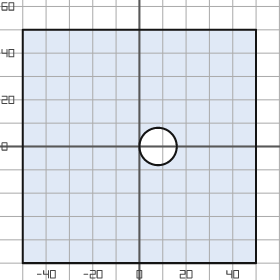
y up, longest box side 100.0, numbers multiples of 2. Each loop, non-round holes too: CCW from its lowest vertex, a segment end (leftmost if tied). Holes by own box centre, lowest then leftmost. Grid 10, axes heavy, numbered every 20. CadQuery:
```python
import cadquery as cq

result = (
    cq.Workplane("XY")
    .moveTo(-50.0, -50.0)
    .lineTo(50.0, -50.0)
    .lineTo(50.0, 50.0)
    .lineTo(-50.0, 50.0)
    .close()
    .moveTo(8.0, 0.0)
    .circle(8.0)
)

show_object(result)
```